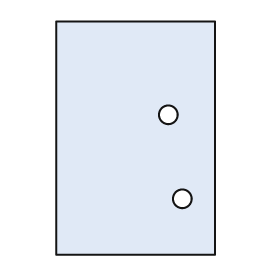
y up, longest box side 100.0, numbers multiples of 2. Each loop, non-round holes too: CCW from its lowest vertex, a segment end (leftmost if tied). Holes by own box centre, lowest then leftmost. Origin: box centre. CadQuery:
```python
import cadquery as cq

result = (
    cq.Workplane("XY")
    .moveTo(-34.0, -50.0)
    .lineTo(34.0, -50.0)
    .lineTo(34.0, 50.0)
    .lineTo(-34.0, 50.0)
    .close()
    .moveTo(20.0, -26.0)
    .circle(4.0)
    .moveTo(14.0, 10.0)
    .circle(4.0)
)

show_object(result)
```